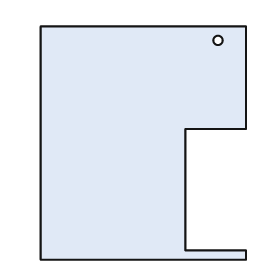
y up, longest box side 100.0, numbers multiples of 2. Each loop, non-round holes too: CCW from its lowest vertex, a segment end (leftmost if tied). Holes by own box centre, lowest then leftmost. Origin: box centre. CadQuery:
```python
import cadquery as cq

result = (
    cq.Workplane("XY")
    .moveTo(-44.0, -50.0)
    .lineTo(44.0, -50.0)
    .lineTo(44.0, -46.0)
    .lineTo(18.0, -46.0)
    .lineTo(18.0, 6.0)
    .lineTo(44.0, 6.0)
    .lineTo(44.0, 50.0)
    .lineTo(-44.0, 50.0)
    .close()
    .moveTo(32.0, 44.0)
    .circle(2.0)
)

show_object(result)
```